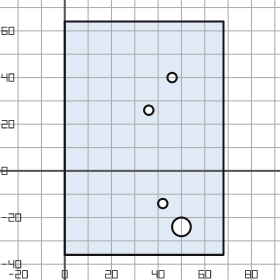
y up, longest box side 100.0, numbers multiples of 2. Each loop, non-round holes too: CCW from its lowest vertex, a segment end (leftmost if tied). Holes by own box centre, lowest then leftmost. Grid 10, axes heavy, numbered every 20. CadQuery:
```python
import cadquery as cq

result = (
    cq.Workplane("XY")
    .moveTo(0.0, -36.0)
    .lineTo(68.0, -36.0)
    .lineTo(68.0, 64.0)
    .lineTo(0.0, 64.0)
    .close()
    .moveTo(50.0, -24.0)
    .circle(4.0)
    .moveTo(42.0, -14.0)
    .circle(2.0)
    .moveTo(36.0, 26.0)
    .circle(2.0)
    .moveTo(46.0, 40.0)
    .circle(2.0)
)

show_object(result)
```